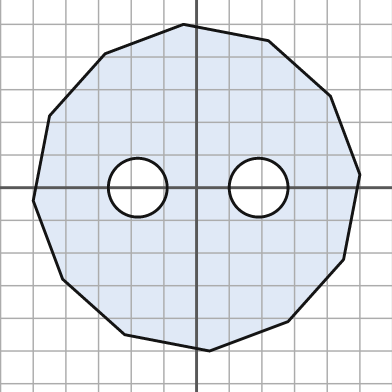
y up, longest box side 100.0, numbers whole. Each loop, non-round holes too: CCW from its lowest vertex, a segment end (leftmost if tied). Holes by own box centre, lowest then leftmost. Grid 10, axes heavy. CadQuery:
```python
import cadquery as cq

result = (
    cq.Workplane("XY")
    .moveTo(4.0, -50.0)
    .lineTo(28.0, -41.0)
    .lineTo(45.0, -22.0)
    .lineTo(50.0, 4.0)
    .lineTo(41.0, 28.0)
    .lineTo(22.0, 45.0)
    .lineTo(-4.0, 50.0)
    .lineTo(-28.0, 41.0)
    .lineTo(-45.0, 22.0)
    .lineTo(-50.0, -4.0)
    .lineTo(-41.0, -28.0)
    .lineTo(-22.0, -45.0)
    .close()
    .moveTo(-18.0, 0.0)
    .circle(9.0)
    .moveTo(19.0, 0.0)
    .circle(9.0)
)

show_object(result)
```